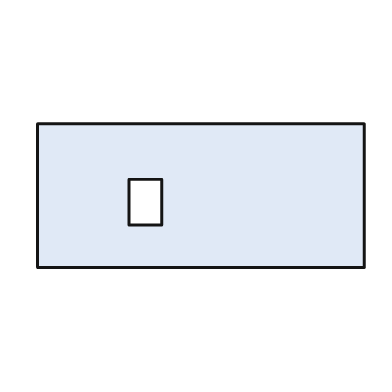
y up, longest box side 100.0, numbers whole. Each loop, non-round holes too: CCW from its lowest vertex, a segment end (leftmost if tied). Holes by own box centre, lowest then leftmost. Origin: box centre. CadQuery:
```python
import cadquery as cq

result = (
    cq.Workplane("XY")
    .moveTo(-50.0, -22.0)
    .lineTo(50.0, -22.0)
    .lineTo(50.0, 22.0)
    .lineTo(-50.0, 22.0)
    .close()
    .moveTo(-22.0, -9.0)
    .lineTo(-12.0, -9.0)
    .lineTo(-12.0, 5.0)
    .lineTo(-22.0, 5.0)
    .close()
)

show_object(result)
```